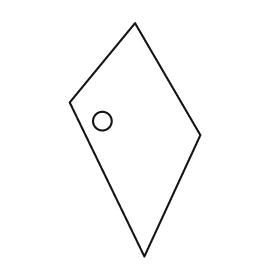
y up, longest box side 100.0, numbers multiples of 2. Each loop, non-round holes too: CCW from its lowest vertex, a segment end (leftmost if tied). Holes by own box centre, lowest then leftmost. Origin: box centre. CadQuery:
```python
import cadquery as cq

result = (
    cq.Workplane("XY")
    .moveTo(4.0, -50.0)
    .lineTo(28.0, 2.0)
    .lineTo(0.0, 50.0)
    .lineTo(-28.0, 16.0)
    .close()
    .moveTo(-14.0, 8.0)
    .circle(4.0)
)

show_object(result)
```